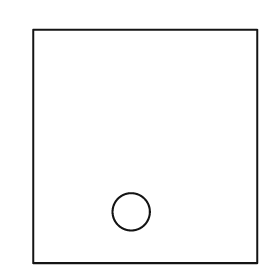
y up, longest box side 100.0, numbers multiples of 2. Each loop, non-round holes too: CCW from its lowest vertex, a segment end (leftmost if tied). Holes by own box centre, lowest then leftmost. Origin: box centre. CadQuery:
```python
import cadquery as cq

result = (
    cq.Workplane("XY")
    .moveTo(-48.0, -50.0)
    .lineTo(48.0, -50.0)
    .lineTo(48.0, 50.0)
    .lineTo(-48.0, 50.0)
    .close()
    .moveTo(-6.0, -28.0)
    .circle(8.0)
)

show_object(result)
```